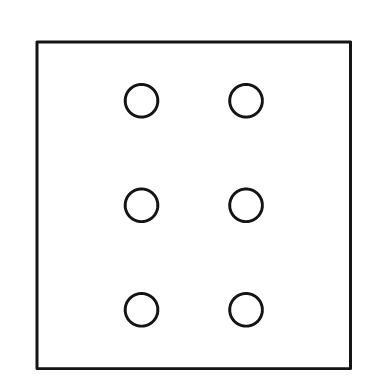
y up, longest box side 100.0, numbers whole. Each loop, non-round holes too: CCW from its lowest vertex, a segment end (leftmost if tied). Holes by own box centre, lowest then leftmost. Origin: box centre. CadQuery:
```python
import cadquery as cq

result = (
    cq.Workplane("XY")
    .moveTo(-48.0, -50.0)
    .lineTo(48.0, -50.0)
    .lineTo(48.0, 50.0)
    .lineTo(-48.0, 50.0)
    .close()
    .moveTo(-16.0, -32.0)
    .circle(5.0)
    .moveTo(16.0, -32.0)
    .circle(5.0)
    .moveTo(-16.0, 0.0)
    .circle(5.0)
    .moveTo(16.0, 0.0)
    .circle(5.0)
    .moveTo(-16.0, 32.0)
    .circle(5.0)
    .moveTo(16.0, 32.0)
    .circle(5.0)
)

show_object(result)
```